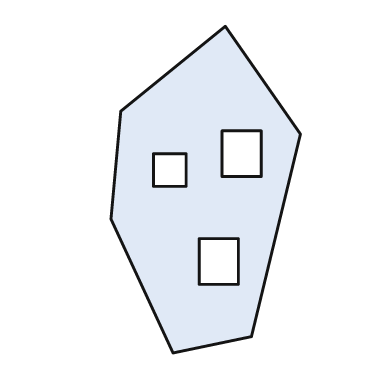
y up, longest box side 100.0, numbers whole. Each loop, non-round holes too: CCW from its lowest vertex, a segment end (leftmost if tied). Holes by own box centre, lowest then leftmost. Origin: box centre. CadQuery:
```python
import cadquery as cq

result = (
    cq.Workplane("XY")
    .moveTo(-10.0, -50.0)
    .lineTo(14.0, -45.0)
    .lineTo(29.0, 17.0)
    .lineTo(6.0, 50.0)
    .lineTo(-26.0, 24.0)
    .lineTo(-29.0, -9.0)
    .close()
    .moveTo(-2.0, -29.0)
    .lineTo(10.0, -29.0)
    .lineTo(10.0, -15.0)
    .lineTo(-2.0, -15.0)
    .close()
    .moveTo(-16.0, 1.0)
    .lineTo(-6.0, 1.0)
    .lineTo(-6.0, 11.0)
    .lineTo(-16.0, 11.0)
    .close()
    .moveTo(5.0, 4.0)
    .lineTo(17.0, 4.0)
    .lineTo(17.0, 18.0)
    .lineTo(5.0, 18.0)
    .close()
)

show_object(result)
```